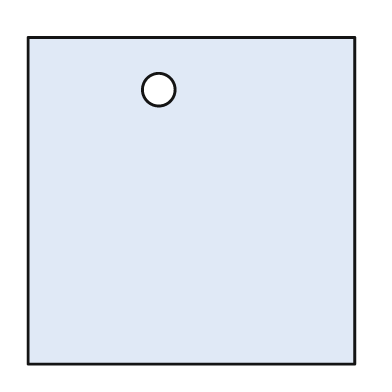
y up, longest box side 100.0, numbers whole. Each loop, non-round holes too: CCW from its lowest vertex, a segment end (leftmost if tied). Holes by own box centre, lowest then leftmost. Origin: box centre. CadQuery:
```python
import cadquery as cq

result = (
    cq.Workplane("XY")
    .moveTo(-50.0, -50.0)
    .lineTo(50.0, -50.0)
    .lineTo(50.0, 50.0)
    .lineTo(-50.0, 50.0)
    .close()
    .moveTo(-10.0, 34.0)
    .circle(5.0)
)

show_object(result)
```